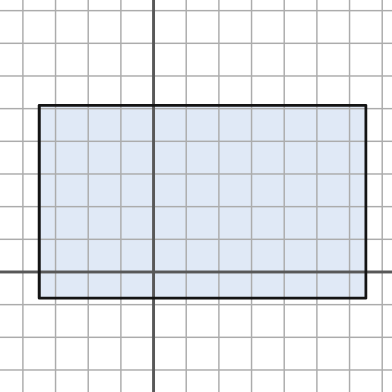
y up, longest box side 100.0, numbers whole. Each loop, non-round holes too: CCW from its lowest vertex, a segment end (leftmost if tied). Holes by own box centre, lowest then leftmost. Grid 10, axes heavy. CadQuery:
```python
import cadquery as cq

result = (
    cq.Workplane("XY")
    .moveTo(-35.0, -8.0)
    .lineTo(65.0, -8.0)
    .lineTo(65.0, 51.0)
    .lineTo(-35.0, 51.0)
    .close()
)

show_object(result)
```